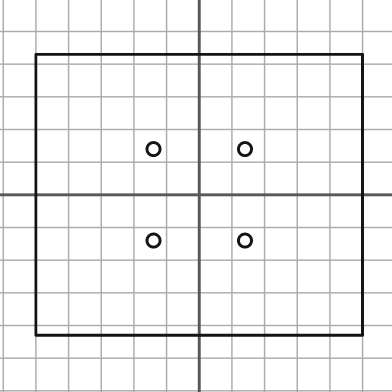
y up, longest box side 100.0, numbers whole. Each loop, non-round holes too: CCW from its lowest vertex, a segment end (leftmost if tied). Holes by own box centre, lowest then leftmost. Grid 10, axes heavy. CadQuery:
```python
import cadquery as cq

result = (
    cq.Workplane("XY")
    .moveTo(-50.0, -43.0)
    .lineTo(50.0, -43.0)
    .lineTo(50.0, 43.0)
    .lineTo(-50.0, 43.0)
    .close()
    .moveTo(-14.0, -14.0)
    .circle(2.0)
    .moveTo(14.0, -14.0)
    .circle(2.0)
    .moveTo(-14.0, 14.0)
    .circle(2.0)
    .moveTo(14.0, 14.0)
    .circle(2.0)
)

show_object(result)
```